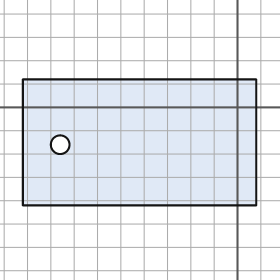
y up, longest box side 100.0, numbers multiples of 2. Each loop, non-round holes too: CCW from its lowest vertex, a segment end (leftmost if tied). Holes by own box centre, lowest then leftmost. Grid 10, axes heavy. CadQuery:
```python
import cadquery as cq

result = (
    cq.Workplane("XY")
    .moveTo(-92.0, -42.0)
    .lineTo(8.0, -42.0)
    .lineTo(8.0, 12.0)
    .lineTo(-92.0, 12.0)
    .close()
    .moveTo(-76.0, -16.0)
    .circle(4.0)
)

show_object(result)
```